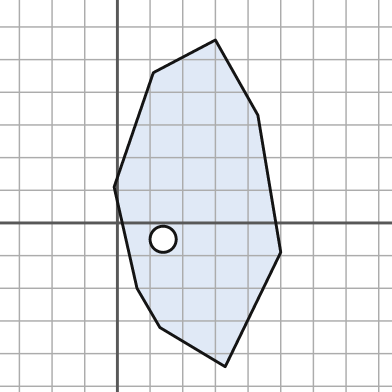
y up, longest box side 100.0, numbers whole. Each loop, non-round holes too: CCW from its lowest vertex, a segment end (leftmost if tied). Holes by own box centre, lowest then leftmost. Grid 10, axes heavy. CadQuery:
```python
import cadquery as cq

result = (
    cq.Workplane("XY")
    .moveTo(33.0, -44.0)
    .lineTo(50.0, -9.0)
    .lineTo(43.0, 33.0)
    .lineTo(30.0, 56.0)
    .lineTo(11.0, 46.0)
    .lineTo(-1.0, 11.0)
    .lineTo(6.0, -20.0)
    .lineTo(13.0, -32.0)
    .close()
    .moveTo(14.0, -5.0)
    .circle(4.0)
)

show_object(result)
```